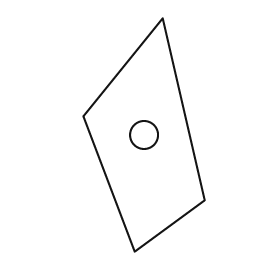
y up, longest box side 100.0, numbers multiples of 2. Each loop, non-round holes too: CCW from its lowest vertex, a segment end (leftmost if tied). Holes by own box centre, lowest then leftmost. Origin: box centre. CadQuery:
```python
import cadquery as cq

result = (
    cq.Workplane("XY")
    .moveTo(-4.0, -50.0)
    .lineTo(26.0, -28.0)
    .lineTo(8.0, 50.0)
    .lineTo(-26.0, 8.0)
    .close()
    .moveTo(0.0, 0.0)
    .circle(6.0)
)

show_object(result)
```